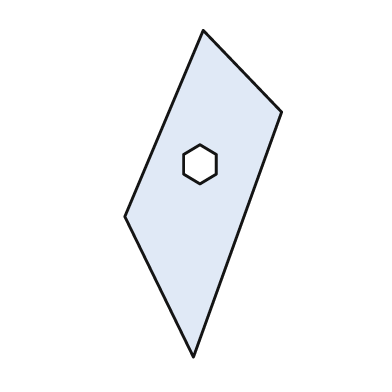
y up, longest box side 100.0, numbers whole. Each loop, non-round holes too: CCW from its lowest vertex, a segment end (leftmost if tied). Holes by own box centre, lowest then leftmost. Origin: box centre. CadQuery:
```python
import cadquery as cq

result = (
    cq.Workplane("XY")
    .moveTo(-3.0, -50.0)
    .lineTo(24.0, 25.0)
    .lineTo(0.0, 50.0)
    .lineTo(-24.0, -7.0)
    .close()
    .moveTo(-1.0, 3.0)
    .lineTo(4.0, 6.0)
    .lineTo(4.0, 12.0)
    .lineTo(-1.0, 15.0)
    .lineTo(-6.0, 12.0)
    .lineTo(-6.0, 6.0)
    .close()
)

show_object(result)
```